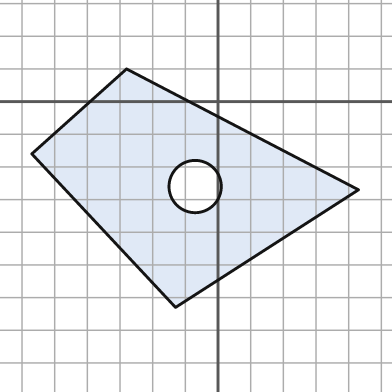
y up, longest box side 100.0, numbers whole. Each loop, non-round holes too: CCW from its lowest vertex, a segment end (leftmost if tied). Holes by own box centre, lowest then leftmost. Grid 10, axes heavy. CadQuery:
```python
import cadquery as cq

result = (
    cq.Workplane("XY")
    .moveTo(-13.0, -63.0)
    .lineTo(43.0, -27.0)
    .lineTo(-28.0, 10.0)
    .lineTo(-57.0, -16.0)
    .close()
    .moveTo(-7.0, -26.0)
    .circle(8.0)
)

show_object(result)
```